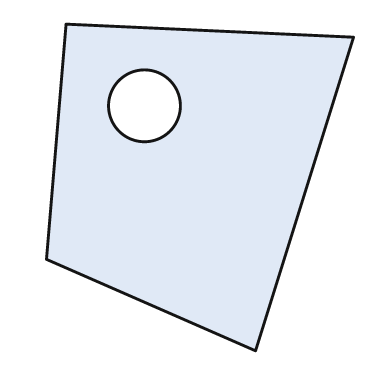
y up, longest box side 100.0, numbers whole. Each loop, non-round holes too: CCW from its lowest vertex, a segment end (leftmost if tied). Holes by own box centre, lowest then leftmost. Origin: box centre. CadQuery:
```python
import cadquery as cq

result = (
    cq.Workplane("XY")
    .moveTo(17.0, -50.0)
    .lineTo(47.0, 46.0)
    .lineTo(-41.0, 50.0)
    .lineTo(-47.0, -22.0)
    .close()
    .moveTo(-17.0, 25.0)
    .circle(11.0)
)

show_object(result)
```